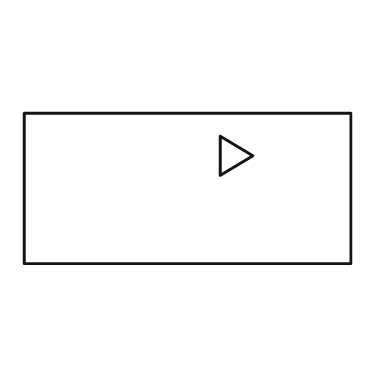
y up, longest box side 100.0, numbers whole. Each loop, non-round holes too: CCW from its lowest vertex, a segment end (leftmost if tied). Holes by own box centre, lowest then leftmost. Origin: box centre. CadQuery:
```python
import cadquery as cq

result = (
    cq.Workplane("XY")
    .moveTo(-50.0, -23.0)
    .lineTo(50.0, -23.0)
    .lineTo(50.0, 23.0)
    .lineTo(-50.0, 23.0)
    .close()
    .moveTo(10.0, 4.0)
    .lineTo(20.0, 10.0)
    .lineTo(10.0, 16.0)
    .close()
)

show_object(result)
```